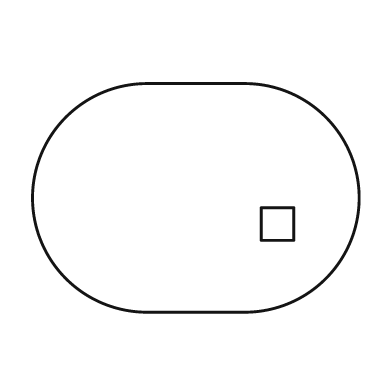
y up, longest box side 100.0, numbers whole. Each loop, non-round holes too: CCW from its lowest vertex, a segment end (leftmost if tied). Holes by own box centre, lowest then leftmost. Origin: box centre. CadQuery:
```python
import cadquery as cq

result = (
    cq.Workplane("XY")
    .moveTo(-15.0, -35.0)
    .lineTo(15.0, -35.0)
    .threePointArc((50.0, 0.0), (15.0, 35.0))
    .lineTo(-15.0, 35.0)
    .threePointArc((-50.0, 0.0), (-15.0, -35.0))
    .close()
    .moveTo(20.0, -13.0)
    .lineTo(30.0, -13.0)
    .lineTo(30.0, -3.0)
    .lineTo(20.0, -3.0)
    .close()
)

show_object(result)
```